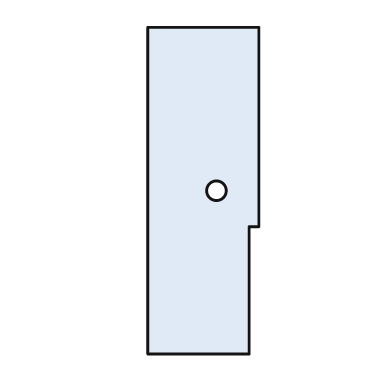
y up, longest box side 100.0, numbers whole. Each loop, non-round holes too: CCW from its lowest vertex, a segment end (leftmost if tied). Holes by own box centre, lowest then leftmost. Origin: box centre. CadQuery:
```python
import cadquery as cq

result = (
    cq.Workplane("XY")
    .moveTo(-17.0, -50.0)
    .lineTo(14.0, -50.0)
    .lineTo(14.0, -11.0)
    .lineTo(17.0, -11.0)
    .lineTo(17.0, 50.0)
    .lineTo(-17.0, 50.0)
    .close()
    .moveTo(4.0, 0.0)
    .circle(3.0)
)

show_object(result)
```